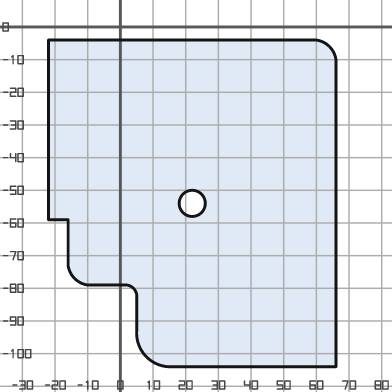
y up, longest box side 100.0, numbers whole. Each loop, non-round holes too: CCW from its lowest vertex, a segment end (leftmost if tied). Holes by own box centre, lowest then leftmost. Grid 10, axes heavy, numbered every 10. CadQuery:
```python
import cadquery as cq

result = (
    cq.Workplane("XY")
    .moveTo(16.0, -104.0)
    .lineTo(66.0, -104.0)
    .lineTo(66.0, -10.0)
    .threePointArc((64.0, -6.0), (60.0, -4.0))
    .lineTo(-22.0, -4.0)
    .lineTo(-22.0, -59.0)
    .lineTo(-16.0, -59.0)
    .lineTo(-16.0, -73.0)
    .threePointArc((-14.0, -77.0), (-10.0, -79.0))
    .lineTo(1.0, -79.0)
    .threePointArc((4.0, -80.0), (5.0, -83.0))
    .lineTo(5.0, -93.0)
    .threePointArc((8.0, -101.0), (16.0, -104.0))
    .close()
    .moveTo(22.0, -54.0)
    .circle(4.0)
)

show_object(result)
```